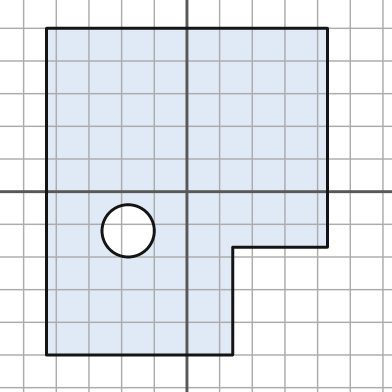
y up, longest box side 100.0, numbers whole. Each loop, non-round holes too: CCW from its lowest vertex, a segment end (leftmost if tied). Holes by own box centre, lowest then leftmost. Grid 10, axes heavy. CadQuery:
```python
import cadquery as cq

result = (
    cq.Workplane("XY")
    .moveTo(-43.0, -50.0)
    .lineTo(14.0, -50.0)
    .lineTo(14.0, -17.0)
    .lineTo(43.0, -17.0)
    .lineTo(43.0, 50.0)
    .lineTo(-43.0, 50.0)
    .close()
    .moveTo(-18.0, -12.0)
    .circle(8.0)
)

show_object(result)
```